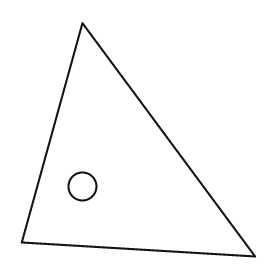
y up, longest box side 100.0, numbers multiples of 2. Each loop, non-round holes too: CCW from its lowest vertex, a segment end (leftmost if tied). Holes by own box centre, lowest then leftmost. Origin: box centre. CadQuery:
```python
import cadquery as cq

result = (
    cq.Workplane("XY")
    .moveTo(50.0, -50.0)
    .lineTo(-24.0, 50.0)
    .lineTo(-50.0, -44.0)
    .close()
    .moveTo(-24.0, -20.0)
    .circle(6.0)
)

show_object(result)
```